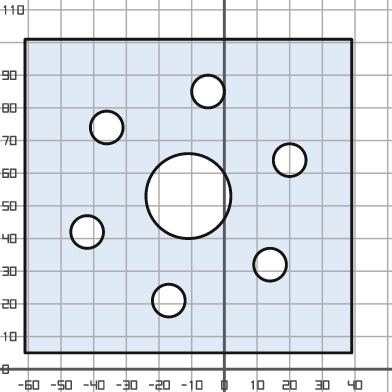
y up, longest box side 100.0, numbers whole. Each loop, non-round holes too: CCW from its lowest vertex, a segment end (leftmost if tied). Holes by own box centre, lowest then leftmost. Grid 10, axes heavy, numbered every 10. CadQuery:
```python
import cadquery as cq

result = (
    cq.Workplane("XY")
    .moveTo(-61.0, 5.0)
    .lineTo(39.0, 5.0)
    .lineTo(39.0, 101.0)
    .lineTo(-61.0, 101.0)
    .close()
    .moveTo(-17.0, 21.0)
    .circle(5.0)
    .moveTo(14.0, 32.0)
    .circle(5.0)
    .moveTo(-42.0, 42.0)
    .circle(5.0)
    .moveTo(-11.0, 53.0)
    .circle(13.0)
    .moveTo(20.0, 64.0)
    .circle(5.0)
    .moveTo(-36.0, 74.0)
    .circle(5.0)
    .moveTo(-5.0, 85.0)
    .circle(5.0)
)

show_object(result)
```